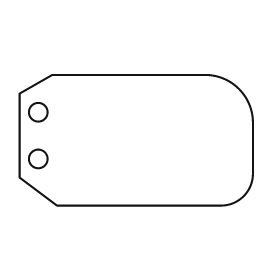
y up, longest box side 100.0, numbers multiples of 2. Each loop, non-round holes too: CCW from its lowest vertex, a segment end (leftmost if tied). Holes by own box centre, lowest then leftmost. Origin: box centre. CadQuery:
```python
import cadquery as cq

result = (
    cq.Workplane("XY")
    .moveTo(-34.0, -28.0)
    .lineTo(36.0, -28.0)
    .threePointArc((46.0, -24.0), (50.0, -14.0))
    .lineTo(50.0, 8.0)
    .threePointArc((44.0, 22.0), (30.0, 28.0))
    .lineTo(-36.0, 28.0)
    .lineTo(-50.0, 20.0)
    .lineTo(-50.0, -16.0)
    .close()
    .moveTo(-42.0, -8.0)
    .circle(4.0)
    .moveTo(-42.0, 12.0)
    .circle(4.0)
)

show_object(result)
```